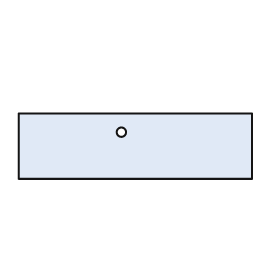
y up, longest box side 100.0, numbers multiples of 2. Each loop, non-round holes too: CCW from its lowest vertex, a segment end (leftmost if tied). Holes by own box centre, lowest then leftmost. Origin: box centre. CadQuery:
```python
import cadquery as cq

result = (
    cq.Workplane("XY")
    .moveTo(-50.0, -14.0)
    .lineTo(50.0, -14.0)
    .lineTo(50.0, 14.0)
    .lineTo(-50.0, 14.0)
    .close()
    .moveTo(-6.0, 6.0)
    .circle(2.0)
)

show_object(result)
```